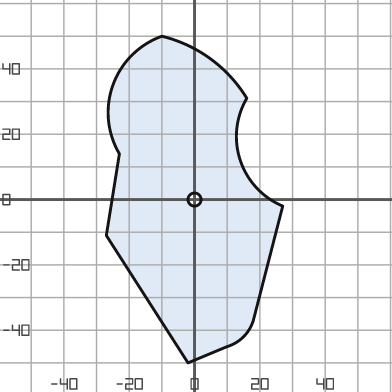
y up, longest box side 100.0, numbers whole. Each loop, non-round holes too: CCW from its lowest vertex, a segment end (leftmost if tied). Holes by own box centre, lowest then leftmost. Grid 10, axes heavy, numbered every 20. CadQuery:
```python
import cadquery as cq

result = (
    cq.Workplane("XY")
    .moveTo(-2.0, -50.0)
    .lineTo(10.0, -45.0)
    .threePointArc((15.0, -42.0), (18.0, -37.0))
    .lineTo(27.0, -2.0)
    .threePointArc((14.0, 12.0), (16.0, 31.0))
    .threePointArc((5.0, 43.0), (-10.0, 50.0))
    .threePointArc((-25.0, 35.0), (-23.0, 14.0))
    .lineTo(-27.0, -11.0)
    .close()
    .moveTo(0.0, 0.0)
    .circle(2.0)
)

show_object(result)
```